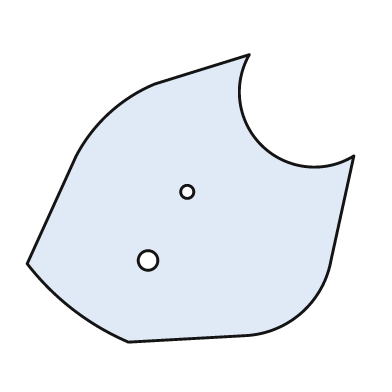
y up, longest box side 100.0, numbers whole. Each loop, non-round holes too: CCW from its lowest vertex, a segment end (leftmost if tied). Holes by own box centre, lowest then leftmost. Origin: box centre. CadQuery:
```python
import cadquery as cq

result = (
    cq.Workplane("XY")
    .moveTo(-19.0, -44.0)
    .lineTo(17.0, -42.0)
    .threePointArc((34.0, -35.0), (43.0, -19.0))
    .lineTo(50.0, 13.0)
    .threePointArc((22.0, 16.0), (18.0, 44.0))
    .lineTo(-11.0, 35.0)
    .threePointArc((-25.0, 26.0), (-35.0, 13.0))
    .lineTo(-50.0, -20.0)
    .threePointArc((-36.0, -34.0), (-19.0, -44.0))
    .close()
    .moveTo(-13.0, -19.0)
    .circle(3.0)
    .moveTo(-1.0, 2.0)
    .circle(2.0)
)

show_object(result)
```